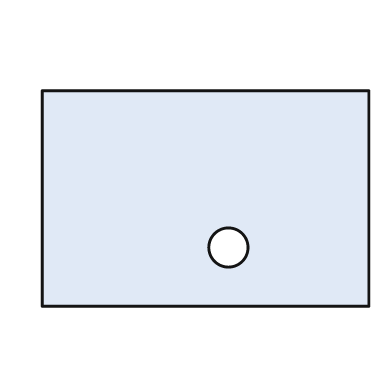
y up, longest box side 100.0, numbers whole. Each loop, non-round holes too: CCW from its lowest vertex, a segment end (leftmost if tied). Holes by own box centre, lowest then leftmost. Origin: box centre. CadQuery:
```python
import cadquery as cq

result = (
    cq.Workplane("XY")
    .moveTo(-50.0, -33.0)
    .lineTo(50.0, -33.0)
    .lineTo(50.0, 33.0)
    .lineTo(-50.0, 33.0)
    .close()
    .moveTo(7.0, -15.0)
    .circle(6.0)
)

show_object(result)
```